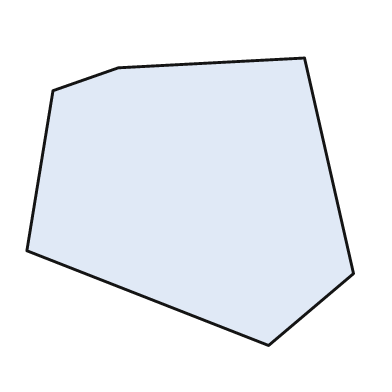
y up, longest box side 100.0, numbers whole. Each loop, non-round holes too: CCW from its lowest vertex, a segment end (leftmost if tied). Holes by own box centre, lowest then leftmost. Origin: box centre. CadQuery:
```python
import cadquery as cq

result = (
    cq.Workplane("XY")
    .moveTo(24.0, -44.0)
    .lineTo(50.0, -22.0)
    .lineTo(35.0, 44.0)
    .lineTo(-22.0, 41.0)
    .lineTo(-42.0, 34.0)
    .lineTo(-50.0, -15.0)
    .close()
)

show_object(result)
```